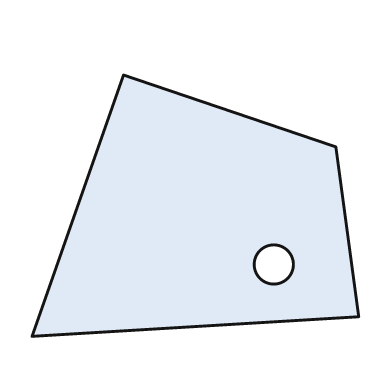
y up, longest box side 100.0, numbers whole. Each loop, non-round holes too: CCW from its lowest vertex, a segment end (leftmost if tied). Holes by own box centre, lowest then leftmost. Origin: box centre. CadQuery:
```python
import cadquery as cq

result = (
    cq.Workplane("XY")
    .moveTo(-50.0, -40.0)
    .lineTo(50.0, -34.0)
    .lineTo(43.0, 18.0)
    .lineTo(-22.0, 40.0)
    .close()
    .moveTo(24.0, -18.0)
    .circle(6.0)
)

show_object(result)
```